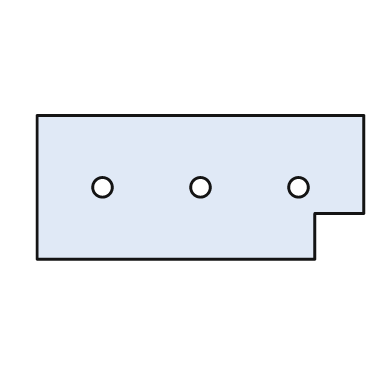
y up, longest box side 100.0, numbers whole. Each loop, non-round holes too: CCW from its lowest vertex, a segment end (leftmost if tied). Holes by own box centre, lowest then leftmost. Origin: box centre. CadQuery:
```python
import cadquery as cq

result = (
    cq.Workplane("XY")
    .moveTo(-50.0, -22.0)
    .lineTo(35.0, -22.0)
    .lineTo(35.0, -8.0)
    .lineTo(50.0, -8.0)
    .lineTo(50.0, 22.0)
    .lineTo(-50.0, 22.0)
    .close()
    .moveTo(-30.0, 0.0)
    .circle(3.0)
    .moveTo(0.0, 0.0)
    .circle(3.0)
    .moveTo(30.0, 0.0)
    .circle(3.0)
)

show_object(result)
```